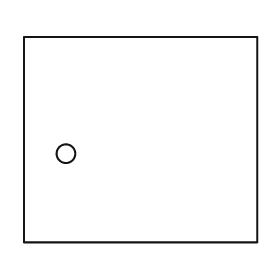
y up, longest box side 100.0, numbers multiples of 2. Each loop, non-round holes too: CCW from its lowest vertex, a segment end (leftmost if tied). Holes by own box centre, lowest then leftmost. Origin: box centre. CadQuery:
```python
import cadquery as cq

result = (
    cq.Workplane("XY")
    .moveTo(-50.0, -44.0)
    .lineTo(50.0, -44.0)
    .lineTo(50.0, 44.0)
    .lineTo(-50.0, 44.0)
    .close()
    .moveTo(-32.0, -6.0)
    .circle(4.0)
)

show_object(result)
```